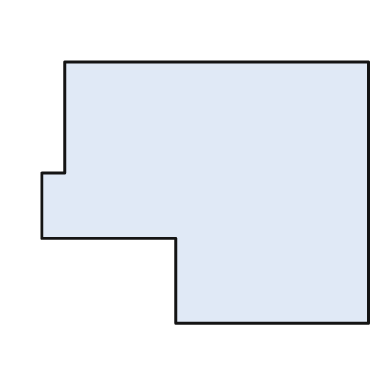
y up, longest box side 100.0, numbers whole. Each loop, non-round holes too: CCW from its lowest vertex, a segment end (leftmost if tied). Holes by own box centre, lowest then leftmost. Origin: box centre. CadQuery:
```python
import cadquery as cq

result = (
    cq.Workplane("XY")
    .moveTo(-9.0, -40.0)
    .lineTo(50.0, -40.0)
    .lineTo(50.0, 40.0)
    .lineTo(-43.0, 40.0)
    .lineTo(-43.0, 6.0)
    .lineTo(-50.0, 6.0)
    .lineTo(-50.0, -14.0)
    .lineTo(-9.0, -14.0)
    .close()
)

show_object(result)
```